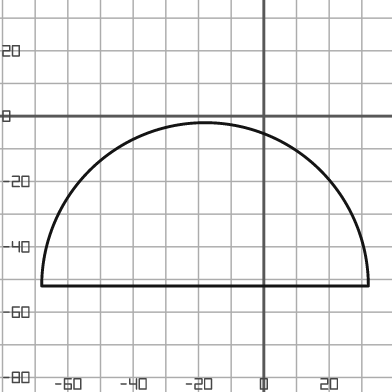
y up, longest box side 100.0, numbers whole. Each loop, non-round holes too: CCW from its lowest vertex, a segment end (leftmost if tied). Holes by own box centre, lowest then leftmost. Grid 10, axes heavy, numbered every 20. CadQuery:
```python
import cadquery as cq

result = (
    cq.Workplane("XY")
    .moveTo(-68.0, -52.0)
    .lineTo(32.0, -52.0)
    .threePointArc((-18.0, -2.0), (-68.0, -52.0))
    .close()
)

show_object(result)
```